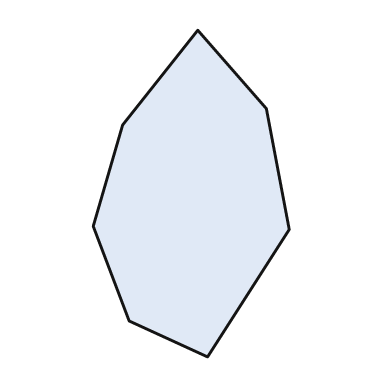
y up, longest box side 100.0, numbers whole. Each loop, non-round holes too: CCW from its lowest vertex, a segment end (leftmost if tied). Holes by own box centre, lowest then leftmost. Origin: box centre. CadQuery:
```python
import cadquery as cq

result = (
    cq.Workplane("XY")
    .moveTo(5.0, -50.0)
    .lineTo(30.0, -11.0)
    .lineTo(23.0, 26.0)
    .lineTo(2.0, 50.0)
    .lineTo(-21.0, 21.0)
    .lineTo(-30.0, -10.0)
    .lineTo(-19.0, -39.0)
    .close()
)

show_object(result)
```